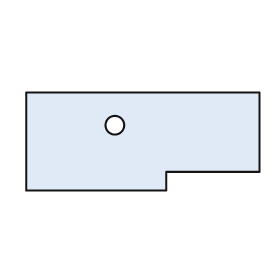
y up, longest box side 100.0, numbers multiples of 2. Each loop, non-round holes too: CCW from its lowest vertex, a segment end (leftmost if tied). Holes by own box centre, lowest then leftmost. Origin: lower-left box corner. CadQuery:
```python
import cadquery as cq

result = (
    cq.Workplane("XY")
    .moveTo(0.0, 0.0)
    .lineTo(60.0, 0.0)
    .lineTo(60.0, 8.0)
    .lineTo(100.0, 8.0)
    .lineTo(100.0, 42.0)
    .lineTo(0.0, 42.0)
    .close()
    .moveTo(38.0, 28.0)
    .circle(4.0)
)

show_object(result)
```